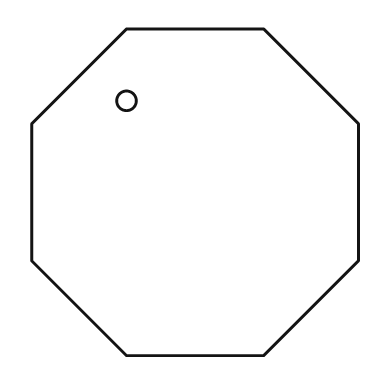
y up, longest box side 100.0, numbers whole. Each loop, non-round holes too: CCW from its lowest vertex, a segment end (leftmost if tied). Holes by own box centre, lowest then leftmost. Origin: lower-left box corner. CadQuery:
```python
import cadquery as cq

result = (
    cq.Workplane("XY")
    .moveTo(29.0, 0.0)
    .lineTo(71.0, 0.0)
    .lineTo(100.0, 29.0)
    .lineTo(100.0, 71.0)
    .lineTo(71.0, 100.0)
    .lineTo(29.0, 100.0)
    .lineTo(0.0, 71.0)
    .lineTo(0.0, 29.0)
    .close()
    .moveTo(29.0, 78.0)
    .circle(3.0)
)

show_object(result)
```